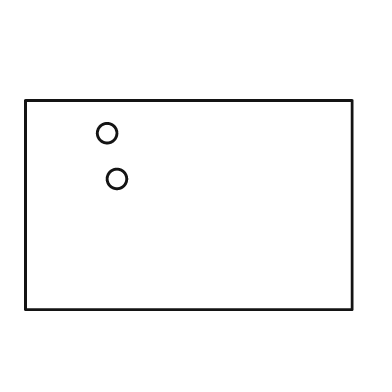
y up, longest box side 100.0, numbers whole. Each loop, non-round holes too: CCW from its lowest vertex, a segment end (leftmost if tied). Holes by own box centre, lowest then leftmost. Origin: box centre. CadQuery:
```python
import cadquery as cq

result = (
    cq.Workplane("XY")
    .moveTo(-50.0, -32.0)
    .lineTo(50.0, -32.0)
    .lineTo(50.0, 32.0)
    .lineTo(-50.0, 32.0)
    .close()
    .moveTo(-22.0, 8.0)
    .circle(3.0)
    .moveTo(-25.0, 22.0)
    .circle(3.0)
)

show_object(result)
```